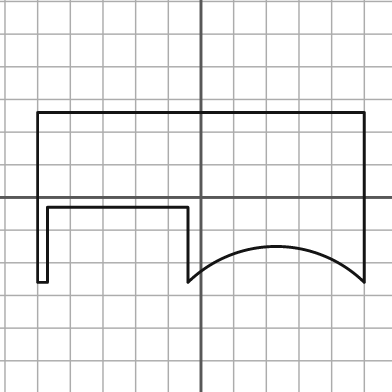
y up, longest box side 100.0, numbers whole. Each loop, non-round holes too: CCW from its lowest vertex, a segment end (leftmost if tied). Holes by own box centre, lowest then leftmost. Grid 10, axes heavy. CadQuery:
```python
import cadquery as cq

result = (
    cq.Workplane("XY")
    .moveTo(-50.0, -26.0)
    .lineTo(-47.0, -26.0)
    .lineTo(-47.0, -3.0)
    .lineTo(-4.0, -3.0)
    .lineTo(-4.0, -26.0)
    .threePointArc((23.0, -15.0), (50.0, -26.0))
    .lineTo(50.0, 26.0)
    .lineTo(-50.0, 26.0)
    .close()
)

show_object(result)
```